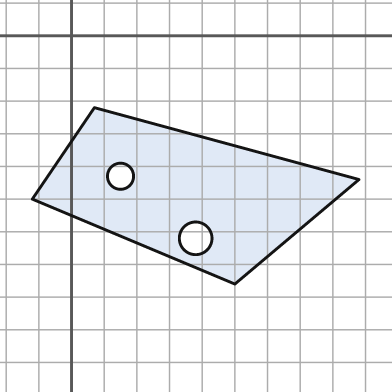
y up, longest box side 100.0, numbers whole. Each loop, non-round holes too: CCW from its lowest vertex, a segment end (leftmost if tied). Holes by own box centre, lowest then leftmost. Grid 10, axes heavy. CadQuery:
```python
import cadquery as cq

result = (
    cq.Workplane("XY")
    .moveTo(50.0, -76.0)
    .lineTo(88.0, -44.0)
    .lineTo(7.0, -22.0)
    .lineTo(-12.0, -50.0)
    .close()
    .moveTo(38.0, -62.0)
    .circle(5.0)
    .moveTo(15.0, -43.0)
    .circle(4.0)
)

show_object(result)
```